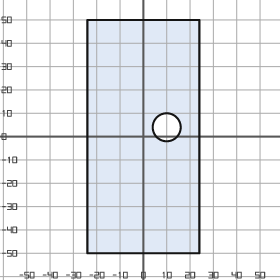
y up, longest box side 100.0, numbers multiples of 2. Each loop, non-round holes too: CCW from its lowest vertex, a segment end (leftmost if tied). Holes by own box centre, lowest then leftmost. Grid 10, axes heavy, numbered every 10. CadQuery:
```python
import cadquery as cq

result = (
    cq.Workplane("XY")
    .moveTo(-24.0, -50.0)
    .lineTo(24.0, -50.0)
    .lineTo(24.0, 50.0)
    .lineTo(-24.0, 50.0)
    .close()
    .moveTo(10.0, 4.0)
    .circle(6.0)
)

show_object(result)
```